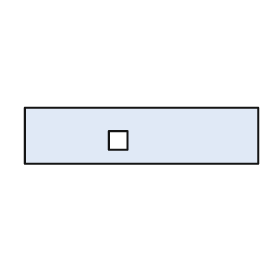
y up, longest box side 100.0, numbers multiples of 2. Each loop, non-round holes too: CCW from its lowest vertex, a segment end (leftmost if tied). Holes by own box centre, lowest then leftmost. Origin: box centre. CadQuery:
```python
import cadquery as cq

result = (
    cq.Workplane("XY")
    .moveTo(-50.0, -12.0)
    .lineTo(50.0, -12.0)
    .lineTo(50.0, 12.0)
    .lineTo(-50.0, 12.0)
    .close()
    .moveTo(-14.0, -6.0)
    .lineTo(-6.0, -6.0)
    .lineTo(-6.0, 2.0)
    .lineTo(-14.0, 2.0)
    .close()
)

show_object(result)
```